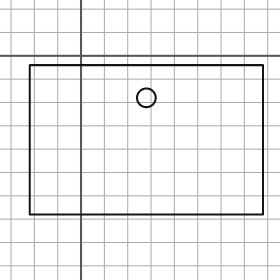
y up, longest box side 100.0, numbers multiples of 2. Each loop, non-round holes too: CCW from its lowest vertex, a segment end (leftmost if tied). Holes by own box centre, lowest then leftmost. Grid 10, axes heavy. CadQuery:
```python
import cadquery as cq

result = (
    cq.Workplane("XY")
    .moveTo(-22.0, -68.0)
    .lineTo(78.0, -68.0)
    .lineTo(78.0, -4.0)
    .lineTo(-22.0, -4.0)
    .close()
    .moveTo(28.0, -18.0)
    .circle(4.0)
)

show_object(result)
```